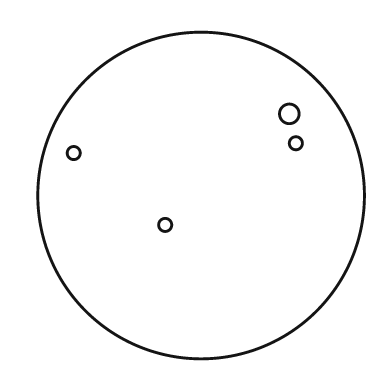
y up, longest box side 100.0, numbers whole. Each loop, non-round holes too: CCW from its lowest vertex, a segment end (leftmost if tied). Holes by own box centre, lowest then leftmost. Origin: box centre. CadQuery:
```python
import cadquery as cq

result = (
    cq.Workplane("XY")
    .moveTo(0.0, 0.0)
    .circle(50.0)
    .moveTo(-11.0, -9.0)
    .circle(2.0)
    .moveTo(-39.0, 13.0)
    .circle(2.0)
    .moveTo(29.0, 16.0)
    .circle(2.0)
    .moveTo(27.0, 25.0)
    .circle(3.0)
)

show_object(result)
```